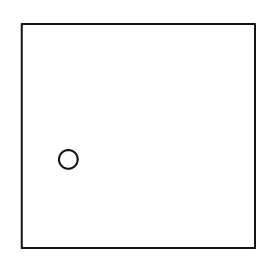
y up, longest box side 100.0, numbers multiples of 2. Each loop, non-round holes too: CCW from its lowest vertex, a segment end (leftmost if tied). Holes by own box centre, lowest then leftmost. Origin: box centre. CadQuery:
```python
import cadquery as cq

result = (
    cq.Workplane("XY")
    .moveTo(-50.0, -48.0)
    .lineTo(50.0, -48.0)
    .lineTo(50.0, 48.0)
    .lineTo(-50.0, 48.0)
    .close()
    .moveTo(-30.0, -10.0)
    .circle(4.0)
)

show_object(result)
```